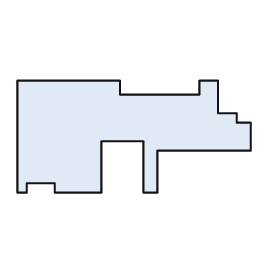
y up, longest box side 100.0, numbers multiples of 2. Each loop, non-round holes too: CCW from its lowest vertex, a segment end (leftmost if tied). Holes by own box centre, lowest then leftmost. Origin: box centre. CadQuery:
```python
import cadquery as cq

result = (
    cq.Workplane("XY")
    .moveTo(-50.0, -24.0)
    .lineTo(-46.0, -24.0)
    .lineTo(-46.0, -20.0)
    .lineTo(-34.0, -20.0)
    .lineTo(-34.0, -24.0)
    .lineTo(-14.0, -24.0)
    .lineTo(-14.0, -2.0)
    .lineTo(4.0, -2.0)
    .lineTo(4.0, -24.0)
    .lineTo(10.0, -24.0)
    .lineTo(10.0, -6.0)
    .lineTo(50.0, -6.0)
    .lineTo(50.0, 6.0)
    .lineTo(44.0, 6.0)
    .lineTo(44.0, 10.0)
    .lineTo(36.0, 10.0)
    .lineTo(36.0, 24.0)
    .lineTo(28.0, 24.0)
    .lineTo(28.0, 18.0)
    .lineTo(-6.0, 18.0)
    .lineTo(-6.0, 24.0)
    .lineTo(-50.0, 24.0)
    .close()
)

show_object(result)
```